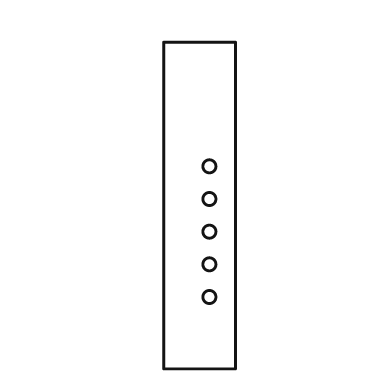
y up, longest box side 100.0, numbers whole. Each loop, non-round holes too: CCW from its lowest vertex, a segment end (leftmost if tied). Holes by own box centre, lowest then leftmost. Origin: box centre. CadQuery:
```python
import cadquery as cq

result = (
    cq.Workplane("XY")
    .moveTo(-11.0, -50.0)
    .lineTo(11.0, -50.0)
    .lineTo(11.0, 50.0)
    .lineTo(-11.0, 50.0)
    .close()
    .moveTo(3.0, -28.0)
    .circle(2.0)
    .moveTo(3.0, -18.0)
    .circle(2.0)
    .moveTo(3.0, -8.0)
    .circle(2.0)
    .moveTo(3.0, 2.0)
    .circle(2.0)
    .moveTo(3.0, 12.0)
    .circle(2.0)
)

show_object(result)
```